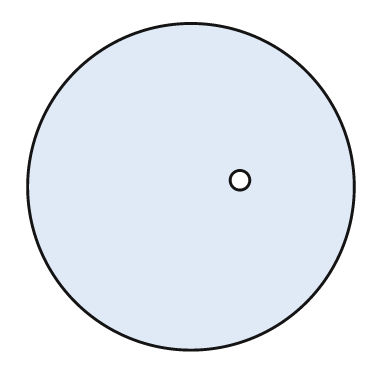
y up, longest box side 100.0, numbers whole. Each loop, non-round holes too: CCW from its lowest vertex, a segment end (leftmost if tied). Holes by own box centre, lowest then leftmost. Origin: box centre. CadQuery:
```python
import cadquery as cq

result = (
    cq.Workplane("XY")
    .moveTo(0.0, 0.0)
    .circle(50.0)
    .moveTo(15.0, 2.0)
    .circle(3.0)
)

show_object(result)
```